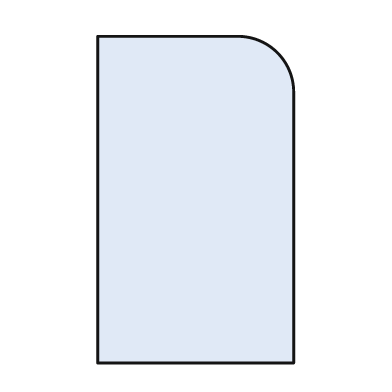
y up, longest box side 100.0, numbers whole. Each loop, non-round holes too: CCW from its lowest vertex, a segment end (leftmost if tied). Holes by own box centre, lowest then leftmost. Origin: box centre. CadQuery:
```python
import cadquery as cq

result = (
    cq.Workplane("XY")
    .moveTo(-30.0, -50.0)
    .lineTo(30.0, -50.0)
    .lineTo(30.0, 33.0)
    .threePointArc((25.0, 45.0), (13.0, 50.0))
    .lineTo(-30.0, 50.0)
    .close()
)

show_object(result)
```